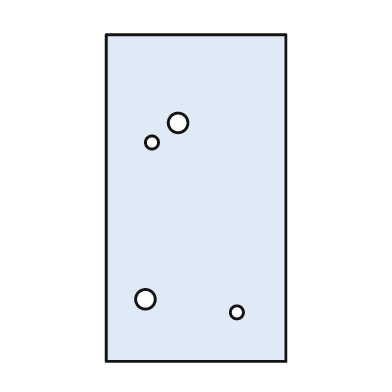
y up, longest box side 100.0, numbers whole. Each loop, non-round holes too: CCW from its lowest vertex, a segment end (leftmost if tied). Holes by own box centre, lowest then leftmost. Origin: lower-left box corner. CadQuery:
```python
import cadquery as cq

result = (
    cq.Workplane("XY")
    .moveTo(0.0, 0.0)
    .lineTo(55.0, 0.0)
    .lineTo(55.0, 100.0)
    .lineTo(0.0, 100.0)
    .close()
    .moveTo(40.0, 15.0)
    .circle(2.0)
    .moveTo(12.0, 19.0)
    .circle(3.0)
    .moveTo(14.0, 67.0)
    .circle(2.0)
    .moveTo(22.0, 73.0)
    .circle(3.0)
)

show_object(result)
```